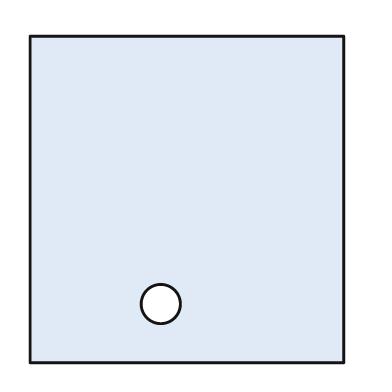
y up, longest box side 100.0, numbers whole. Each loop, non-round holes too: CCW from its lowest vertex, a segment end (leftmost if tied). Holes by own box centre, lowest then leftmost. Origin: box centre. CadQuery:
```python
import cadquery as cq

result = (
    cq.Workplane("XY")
    .moveTo(-48.0, -50.0)
    .lineTo(48.0, -50.0)
    .lineTo(48.0, 50.0)
    .lineTo(-48.0, 50.0)
    .close()
    .moveTo(-8.0, -32.0)
    .circle(6.0)
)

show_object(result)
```